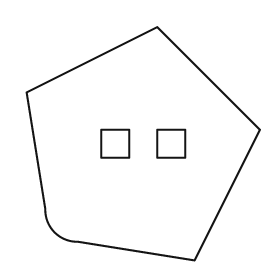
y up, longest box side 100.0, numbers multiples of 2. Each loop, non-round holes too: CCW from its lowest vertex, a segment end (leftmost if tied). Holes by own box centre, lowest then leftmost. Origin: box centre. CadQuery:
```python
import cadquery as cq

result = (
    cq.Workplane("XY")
    .moveTo(22.0, -50.0)
    .lineTo(50.0, 6.0)
    .lineTo(6.0, 50.0)
    .lineTo(-50.0, 22.0)
    .lineTo(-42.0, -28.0)
    .threePointArc((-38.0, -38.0), (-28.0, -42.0))
    .close()
    .moveTo(-18.0, -6.0)
    .lineTo(-6.0, -6.0)
    .lineTo(-6.0, 6.0)
    .lineTo(-18.0, 6.0)
    .close()
    .moveTo(6.0, -6.0)
    .lineTo(18.0, -6.0)
    .lineTo(18.0, 6.0)
    .lineTo(6.0, 6.0)
    .close()
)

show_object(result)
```